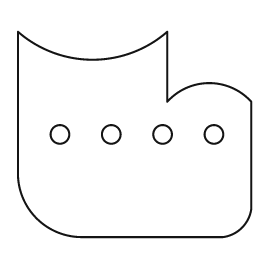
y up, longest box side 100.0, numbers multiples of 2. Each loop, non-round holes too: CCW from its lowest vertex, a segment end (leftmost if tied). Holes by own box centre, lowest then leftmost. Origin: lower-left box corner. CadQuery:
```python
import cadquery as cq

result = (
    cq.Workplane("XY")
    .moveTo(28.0, 0.0)
    .lineTo(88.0, 0.0)
    .threePointArc((96.0, 4.0), (100.0, 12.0))
    .lineTo(100.0, 58.0)
    .threePointArc((82.0, 66.0), (64.0, 58.0))
    .lineTo(64.0, 88.0)
    .threePointArc((32.0, 76.0), (0.0, 88.0))
    .lineTo(0.0, 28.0)
    .threePointArc((8.0, 8.0), (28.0, 0.0))
    .close()
    .moveTo(18.0, 44.0)
    .circle(4.0)
    .moveTo(40.0, 44.0)
    .circle(4.0)
    .moveTo(62.0, 44.0)
    .circle(4.0)
    .moveTo(84.0, 44.0)
    .circle(4.0)
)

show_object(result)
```